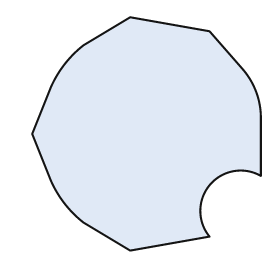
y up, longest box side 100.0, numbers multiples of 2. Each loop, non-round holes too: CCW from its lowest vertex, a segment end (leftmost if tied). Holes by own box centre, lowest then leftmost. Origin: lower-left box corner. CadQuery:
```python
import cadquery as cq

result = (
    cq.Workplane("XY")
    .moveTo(42.0, 0.0)
    .lineTo(76.0, 6.0)
    .threePointArc((76.0, 28.0), (98.0, 32.0))
    .lineTo(98.0, 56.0)
    .threePointArc((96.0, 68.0), (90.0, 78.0))
    .lineTo(76.0, 94.0)
    .lineTo(42.0, 100.0)
    .lineTo(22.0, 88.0)
    .threePointArc((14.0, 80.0), (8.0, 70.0))
    .lineTo(0.0, 50.0)
    .lineTo(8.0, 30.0)
    .threePointArc((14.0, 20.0), (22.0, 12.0))
    .close()
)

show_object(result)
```